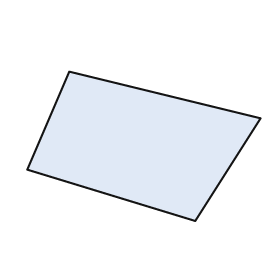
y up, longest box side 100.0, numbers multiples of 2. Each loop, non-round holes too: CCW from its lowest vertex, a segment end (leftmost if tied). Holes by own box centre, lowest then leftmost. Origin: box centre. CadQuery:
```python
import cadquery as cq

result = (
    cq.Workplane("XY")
    .moveTo(22.0, -32.0)
    .lineTo(50.0, 12.0)
    .lineTo(-32.0, 32.0)
    .lineTo(-50.0, -10.0)
    .close()
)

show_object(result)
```